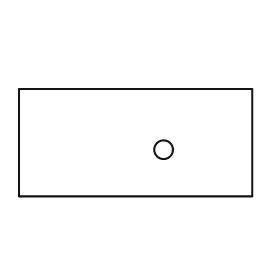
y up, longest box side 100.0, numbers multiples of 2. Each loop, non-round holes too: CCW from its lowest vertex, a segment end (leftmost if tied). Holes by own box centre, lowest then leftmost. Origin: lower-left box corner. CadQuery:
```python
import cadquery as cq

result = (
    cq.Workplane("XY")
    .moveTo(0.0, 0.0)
    .lineTo(100.0, 0.0)
    .lineTo(100.0, 46.0)
    .lineTo(0.0, 46.0)
    .close()
    .moveTo(62.0, 20.0)
    .circle(4.0)
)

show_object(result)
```